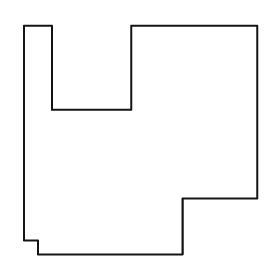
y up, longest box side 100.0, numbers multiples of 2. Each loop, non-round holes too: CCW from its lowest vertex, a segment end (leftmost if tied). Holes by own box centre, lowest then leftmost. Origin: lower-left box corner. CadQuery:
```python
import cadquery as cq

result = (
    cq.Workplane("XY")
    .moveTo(6.0, 0.0)
    .lineTo(68.0, 0.0)
    .lineTo(68.0, 24.0)
    .lineTo(100.0, 24.0)
    .lineTo(100.0, 98.0)
    .lineTo(46.0, 98.0)
    .lineTo(46.0, 62.0)
    .lineTo(12.0, 62.0)
    .lineTo(12.0, 98.0)
    .lineTo(0.0, 98.0)
    .lineTo(0.0, 6.0)
    .lineTo(6.0, 6.0)
    .close()
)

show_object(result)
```